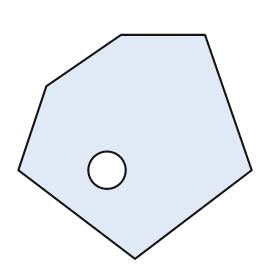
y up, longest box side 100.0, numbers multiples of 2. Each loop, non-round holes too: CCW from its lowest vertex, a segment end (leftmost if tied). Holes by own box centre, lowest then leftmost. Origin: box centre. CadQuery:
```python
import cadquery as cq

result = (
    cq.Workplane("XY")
    .moveTo(0.0, -48.0)
    .lineTo(50.0, -10.0)
    .lineTo(30.0, 48.0)
    .lineTo(-6.0, 48.0)
    .lineTo(-38.0, 26.0)
    .lineTo(-50.0, -10.0)
    .close()
    .moveTo(-12.0, -10.0)
    .circle(8.0)
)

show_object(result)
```